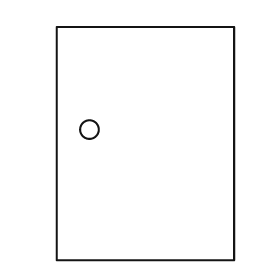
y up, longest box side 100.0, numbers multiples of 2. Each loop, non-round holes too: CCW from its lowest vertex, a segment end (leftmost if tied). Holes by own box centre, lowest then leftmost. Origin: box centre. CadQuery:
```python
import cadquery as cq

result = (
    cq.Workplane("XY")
    .moveTo(-38.0, -50.0)
    .lineTo(38.0, -50.0)
    .lineTo(38.0, 50.0)
    .lineTo(-38.0, 50.0)
    .close()
    .moveTo(-24.0, 6.0)
    .circle(4.0)
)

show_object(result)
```